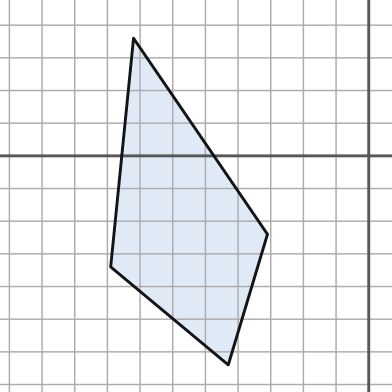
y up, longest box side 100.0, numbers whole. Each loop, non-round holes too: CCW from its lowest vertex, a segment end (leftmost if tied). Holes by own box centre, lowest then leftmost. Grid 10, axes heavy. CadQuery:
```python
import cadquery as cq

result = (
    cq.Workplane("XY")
    .moveTo(-43.0, -64.0)
    .lineTo(-31.0, -24.0)
    .lineTo(-72.0, 36.0)
    .lineTo(-79.0, -34.0)
    .close()
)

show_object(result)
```